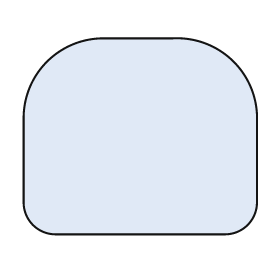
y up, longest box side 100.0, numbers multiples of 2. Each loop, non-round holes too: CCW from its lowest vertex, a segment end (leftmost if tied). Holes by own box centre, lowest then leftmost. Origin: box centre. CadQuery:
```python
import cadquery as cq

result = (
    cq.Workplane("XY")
    .moveTo(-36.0, -42.0)
    .lineTo(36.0, -42.0)
    .threePointArc((46.0, -38.0), (50.0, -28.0))
    .lineTo(50.0, 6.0)
    .threePointArc((40.0, 32.0), (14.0, 42.0))
    .lineTo(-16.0, 42.0)
    .threePointArc((-40.0, 32.0), (-50.0, 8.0))
    .lineTo(-50.0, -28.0)
    .threePointArc((-46.0, -38.0), (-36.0, -42.0))
    .close()
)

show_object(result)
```